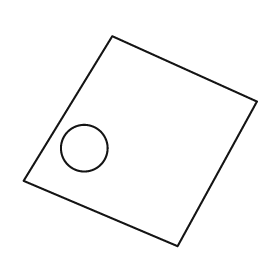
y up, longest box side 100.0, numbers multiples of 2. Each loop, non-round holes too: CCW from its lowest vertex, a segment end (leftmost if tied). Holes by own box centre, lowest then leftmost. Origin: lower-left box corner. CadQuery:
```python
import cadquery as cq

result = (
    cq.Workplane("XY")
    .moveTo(66.0, 0.0)
    .lineTo(100.0, 62.0)
    .lineTo(38.0, 90.0)
    .lineTo(0.0, 28.0)
    .close()
    .moveTo(26.0, 42.0)
    .circle(10.0)
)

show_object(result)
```